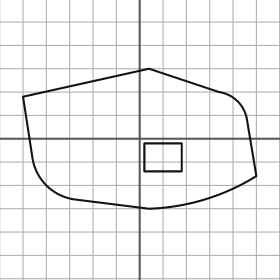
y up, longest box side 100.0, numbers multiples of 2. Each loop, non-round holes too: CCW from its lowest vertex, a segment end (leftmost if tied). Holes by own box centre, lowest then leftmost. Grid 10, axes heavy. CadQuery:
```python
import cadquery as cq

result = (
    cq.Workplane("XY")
    .moveTo(4.0, -30.0)
    .threePointArc((28.0, -26.0), (50.0, -16.0))
    .lineTo(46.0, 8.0)
    .threePointArc((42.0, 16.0), (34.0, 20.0))
    .lineTo(4.0, 30.0)
    .lineTo(-50.0, 18.0)
    .lineTo(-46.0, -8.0)
    .threePointArc((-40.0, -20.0), (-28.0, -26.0))
    .close()
    .moveTo(2.0, -14.0)
    .lineTo(18.0, -14.0)
    .lineTo(18.0, -2.0)
    .lineTo(2.0, -2.0)
    .close()
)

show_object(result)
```